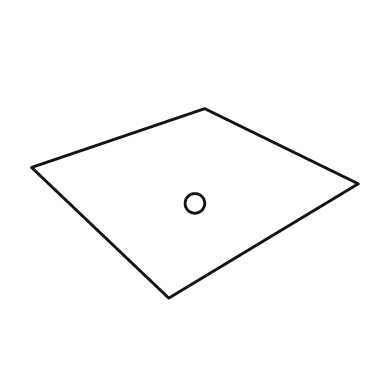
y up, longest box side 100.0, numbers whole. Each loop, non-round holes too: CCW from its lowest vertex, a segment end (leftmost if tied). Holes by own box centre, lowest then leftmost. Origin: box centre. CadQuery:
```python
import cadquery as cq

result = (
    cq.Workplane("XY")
    .moveTo(-8.0, -29.0)
    .lineTo(50.0, 6.0)
    .lineTo(3.0, 29.0)
    .lineTo(-50.0, 11.0)
    .close()
    .moveTo(0.0, 0.0)
    .circle(3.0)
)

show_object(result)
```